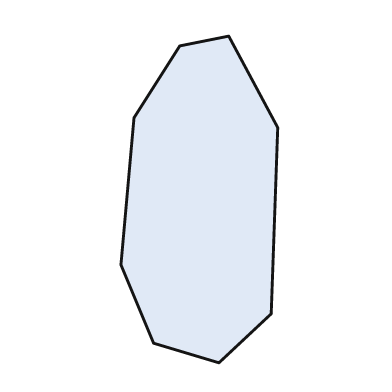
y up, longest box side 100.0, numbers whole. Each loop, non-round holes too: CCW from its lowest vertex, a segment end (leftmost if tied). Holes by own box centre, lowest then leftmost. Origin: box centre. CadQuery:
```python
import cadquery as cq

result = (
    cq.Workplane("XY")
    .moveTo(6.0, -50.0)
    .lineTo(22.0, -35.0)
    .lineTo(24.0, 22.0)
    .lineTo(9.0, 50.0)
    .lineTo(-6.0, 47.0)
    .lineTo(-20.0, 25.0)
    .lineTo(-24.0, -20.0)
    .lineTo(-14.0, -44.0)
    .close()
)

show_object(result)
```